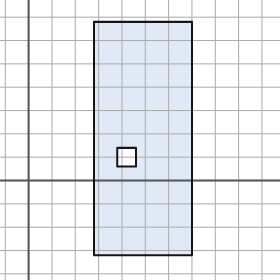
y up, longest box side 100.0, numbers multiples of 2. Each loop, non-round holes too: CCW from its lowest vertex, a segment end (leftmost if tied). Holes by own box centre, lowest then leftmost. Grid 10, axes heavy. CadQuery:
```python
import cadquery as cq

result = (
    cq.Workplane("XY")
    .moveTo(28.0, -32.0)
    .lineTo(70.0, -32.0)
    .lineTo(70.0, 68.0)
    .lineTo(28.0, 68.0)
    .close()
    .moveTo(38.0, 6.0)
    .lineTo(46.0, 6.0)
    .lineTo(46.0, 14.0)
    .lineTo(38.0, 14.0)
    .close()
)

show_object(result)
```